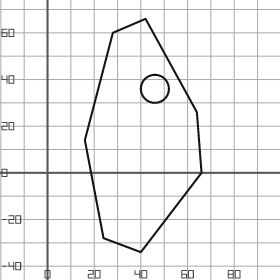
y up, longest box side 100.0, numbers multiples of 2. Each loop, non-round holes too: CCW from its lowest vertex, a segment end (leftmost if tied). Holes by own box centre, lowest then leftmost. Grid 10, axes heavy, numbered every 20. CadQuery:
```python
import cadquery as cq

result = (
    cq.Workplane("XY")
    .moveTo(40.0, -34.0)
    .lineTo(66.0, 0.0)
    .lineTo(64.0, 26.0)
    .lineTo(42.0, 66.0)
    .lineTo(28.0, 60.0)
    .lineTo(16.0, 14.0)
    .lineTo(24.0, -28.0)
    .close()
    .moveTo(46.0, 36.0)
    .circle(6.0)
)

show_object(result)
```